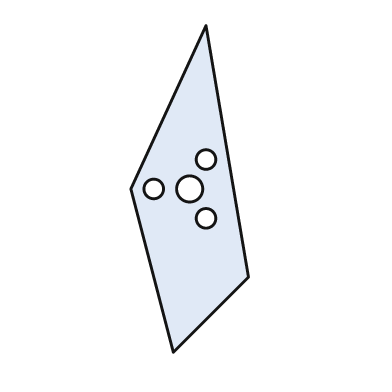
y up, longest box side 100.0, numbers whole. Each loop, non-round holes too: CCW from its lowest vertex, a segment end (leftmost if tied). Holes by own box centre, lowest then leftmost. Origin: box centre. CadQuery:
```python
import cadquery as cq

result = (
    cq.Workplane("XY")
    .moveTo(-5.0, -50.0)
    .lineTo(18.0, -27.0)
    .lineTo(5.0, 50.0)
    .lineTo(-18.0, 0.0)
    .close()
    .moveTo(5.0, -9.0)
    .circle(3.0)
    .moveTo(-11.0, 0.0)
    .circle(3.0)
    .moveTo(0.0, 0.0)
    .circle(4.0)
    .moveTo(5.0, 9.0)
    .circle(3.0)
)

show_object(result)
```